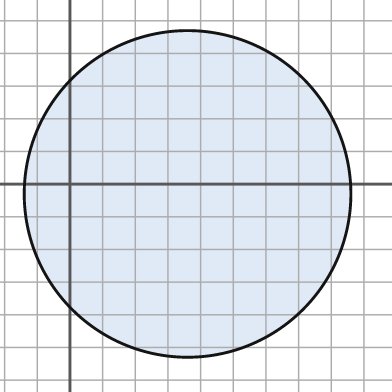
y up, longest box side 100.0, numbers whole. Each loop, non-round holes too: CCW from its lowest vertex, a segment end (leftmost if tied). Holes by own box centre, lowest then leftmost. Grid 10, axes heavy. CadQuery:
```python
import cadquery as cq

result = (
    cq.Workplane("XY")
    .moveTo(36.0, -3.0)
    .circle(50.0)
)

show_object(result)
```